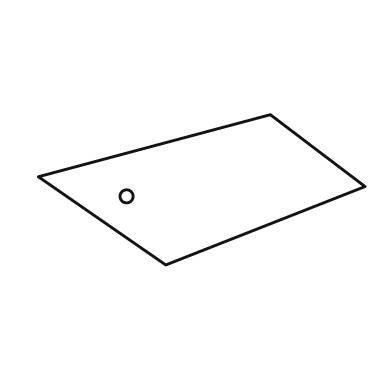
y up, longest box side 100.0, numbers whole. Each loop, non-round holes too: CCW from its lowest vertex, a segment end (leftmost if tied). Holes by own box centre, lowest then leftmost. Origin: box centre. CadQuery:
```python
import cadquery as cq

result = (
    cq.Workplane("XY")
    .moveTo(-11.0, -23.0)
    .lineTo(50.0, 1.0)
    .lineTo(21.0, 23.0)
    .lineTo(-50.0, 4.0)
    .close()
    .moveTo(-23.0, -2.0)
    .circle(2.0)
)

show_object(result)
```